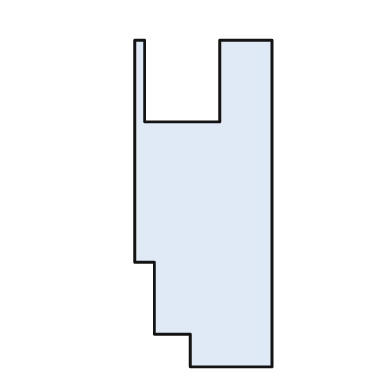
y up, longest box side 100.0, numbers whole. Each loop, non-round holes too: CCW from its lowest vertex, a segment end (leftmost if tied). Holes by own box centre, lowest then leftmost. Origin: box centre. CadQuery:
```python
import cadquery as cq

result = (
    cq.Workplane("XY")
    .moveTo(-4.0, -50.0)
    .lineTo(21.0, -50.0)
    .lineTo(21.0, 50.0)
    .lineTo(5.0, 50.0)
    .lineTo(5.0, 25.0)
    .lineTo(-18.0, 25.0)
    .lineTo(-18.0, 50.0)
    .lineTo(-21.0, 50.0)
    .lineTo(-21.0, -18.0)
    .lineTo(-15.0, -18.0)
    .lineTo(-15.0, -40.0)
    .lineTo(-4.0, -40.0)
    .close()
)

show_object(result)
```